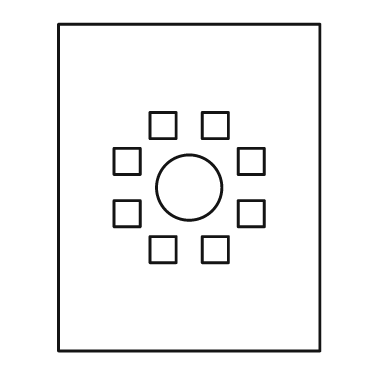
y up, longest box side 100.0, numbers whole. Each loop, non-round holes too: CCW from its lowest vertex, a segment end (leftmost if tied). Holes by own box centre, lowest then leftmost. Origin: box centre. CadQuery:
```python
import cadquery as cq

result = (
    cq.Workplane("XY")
    .moveTo(-40.0, -50.0)
    .lineTo(40.0, -50.0)
    .lineTo(40.0, 50.0)
    .lineTo(-40.0, 50.0)
    .close()
    .moveTo(-12.0, -23.0)
    .lineTo(-4.0, -23.0)
    .lineTo(-4.0, -15.0)
    .lineTo(-12.0, -15.0)
    .close()
    .moveTo(4.0, -23.0)
    .lineTo(12.0, -23.0)
    .lineTo(12.0, -15.0)
    .lineTo(4.0, -15.0)
    .close()
    .moveTo(-23.0, -12.0)
    .lineTo(-15.0, -12.0)
    .lineTo(-15.0, -4.0)
    .lineTo(-23.0, -4.0)
    .close()
    .moveTo(15.0, -12.0)
    .lineTo(23.0, -12.0)
    .lineTo(23.0, -4.0)
    .lineTo(15.0, -4.0)
    .close()
    .moveTo(0.0, 0.0)
    .circle(10.0)
    .moveTo(-23.0, 4.0)
    .lineTo(-15.0, 4.0)
    .lineTo(-15.0, 12.0)
    .lineTo(-23.0, 12.0)
    .close()
    .moveTo(15.0, 4.0)
    .lineTo(23.0, 4.0)
    .lineTo(23.0, 12.0)
    .lineTo(15.0, 12.0)
    .close()
    .moveTo(-12.0, 15.0)
    .lineTo(-4.0, 15.0)
    .lineTo(-4.0, 23.0)
    .lineTo(-12.0, 23.0)
    .close()
    .moveTo(4.0, 15.0)
    .lineTo(12.0, 15.0)
    .lineTo(12.0, 23.0)
    .lineTo(4.0, 23.0)
    .close()
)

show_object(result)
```